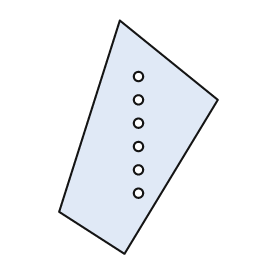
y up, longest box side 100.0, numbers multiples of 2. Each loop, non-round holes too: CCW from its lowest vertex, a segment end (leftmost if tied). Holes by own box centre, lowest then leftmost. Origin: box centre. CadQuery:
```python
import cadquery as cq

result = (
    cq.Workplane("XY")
    .moveTo(-6.0, -50.0)
    .lineTo(34.0, 16.0)
    .lineTo(-8.0, 50.0)
    .lineTo(-34.0, -32.0)
    .close()
    .moveTo(0.0, -24.0)
    .circle(2.0)
    .moveTo(0.0, -14.0)
    .circle(2.0)
    .moveTo(0.0, -4.0)
    .circle(2.0)
    .moveTo(0.0, 6.0)
    .circle(2.0)
    .moveTo(0.0, 16.0)
    .circle(2.0)
    .moveTo(0.0, 26.0)
    .circle(2.0)
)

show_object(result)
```